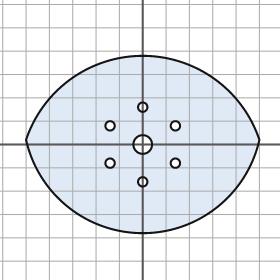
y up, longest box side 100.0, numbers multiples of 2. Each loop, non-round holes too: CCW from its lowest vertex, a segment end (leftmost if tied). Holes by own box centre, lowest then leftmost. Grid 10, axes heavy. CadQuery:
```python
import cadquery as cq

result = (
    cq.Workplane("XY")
    .moveTo(-50.0, 2.0)
    .threePointArc((0.0, -38.0), (50.0, 2.0))
    .threePointArc((0.0, 38.0), (-50.0, 2.0))
    .close()
    .moveTo(0.0, -16.0)
    .circle(2.0)
    .moveTo(-14.0, -8.0)
    .circle(2.0)
    .moveTo(14.0, -8.0)
    .circle(2.0)
    .moveTo(0.0, 0.0)
    .circle(4.0)
    .moveTo(-14.0, 8.0)
    .circle(2.0)
    .moveTo(14.0, 8.0)
    .circle(2.0)
    .moveTo(0.0, 16.0)
    .circle(2.0)
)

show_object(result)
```